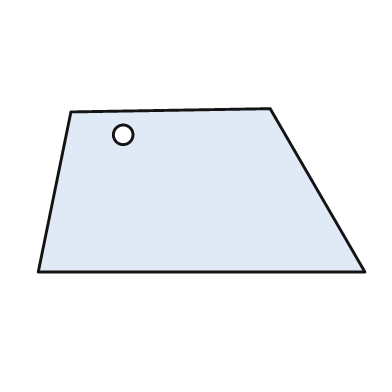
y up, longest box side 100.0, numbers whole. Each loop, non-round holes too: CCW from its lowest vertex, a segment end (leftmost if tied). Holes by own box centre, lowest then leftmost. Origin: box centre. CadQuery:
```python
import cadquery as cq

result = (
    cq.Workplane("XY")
    .moveTo(-50.0, -25.0)
    .lineTo(50.0, -25.0)
    .lineTo(21.0, 25.0)
    .lineTo(-40.0, 24.0)
    .close()
    .moveTo(-24.0, 17.0)
    .circle(3.0)
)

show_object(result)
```